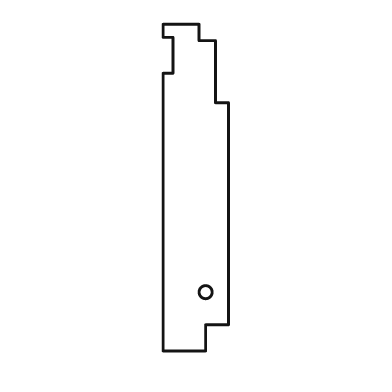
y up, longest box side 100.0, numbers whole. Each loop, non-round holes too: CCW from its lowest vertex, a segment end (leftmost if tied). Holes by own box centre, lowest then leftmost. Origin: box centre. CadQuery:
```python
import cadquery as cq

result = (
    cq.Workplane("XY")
    .moveTo(-10.0, -50.0)
    .lineTo(3.0, -50.0)
    .lineTo(3.0, -42.0)
    .lineTo(10.0, -42.0)
    .lineTo(10.0, 26.0)
    .lineTo(6.0, 26.0)
    .lineTo(6.0, 45.0)
    .lineTo(1.0, 45.0)
    .lineTo(1.0, 50.0)
    .lineTo(-10.0, 50.0)
    .lineTo(-10.0, 46.0)
    .lineTo(-7.0, 46.0)
    .lineTo(-7.0, 35.0)
    .lineTo(-10.0, 35.0)
    .close()
    .moveTo(3.0, -32.0)
    .circle(2.0)
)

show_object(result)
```